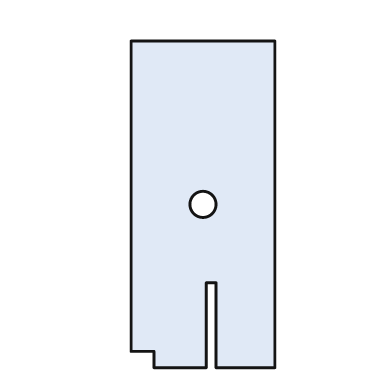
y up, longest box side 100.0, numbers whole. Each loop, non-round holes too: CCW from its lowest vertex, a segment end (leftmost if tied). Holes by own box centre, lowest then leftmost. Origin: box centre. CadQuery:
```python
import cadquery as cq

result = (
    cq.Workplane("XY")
    .moveTo(-15.0, -50.0)
    .lineTo(1.0, -50.0)
    .lineTo(1.0, -24.0)
    .lineTo(4.0, -24.0)
    .lineTo(4.0, -50.0)
    .lineTo(22.0, -50.0)
    .lineTo(22.0, 50.0)
    .lineTo(-22.0, 50.0)
    .lineTo(-22.0, -45.0)
    .lineTo(-15.0, -45.0)
    .close()
    .moveTo(0.0, 0.0)
    .circle(4.0)
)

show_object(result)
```